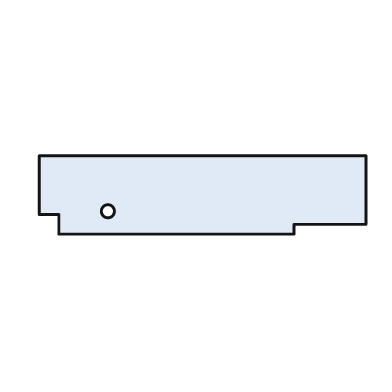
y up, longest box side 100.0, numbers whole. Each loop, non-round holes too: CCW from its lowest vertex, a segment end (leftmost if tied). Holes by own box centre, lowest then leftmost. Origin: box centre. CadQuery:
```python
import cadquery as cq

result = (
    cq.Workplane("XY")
    .moveTo(-44.0, -12.0)
    .lineTo(28.0, -12.0)
    .lineTo(28.0, -9.0)
    .lineTo(50.0, -9.0)
    .lineTo(50.0, 12.0)
    .lineTo(-50.0, 12.0)
    .lineTo(-50.0, -6.0)
    .lineTo(-44.0, -6.0)
    .close()
    .moveTo(-29.0, -5.0)
    .circle(2.0)
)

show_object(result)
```